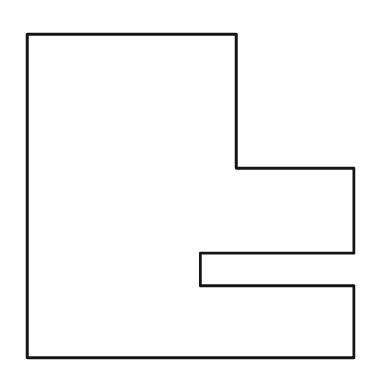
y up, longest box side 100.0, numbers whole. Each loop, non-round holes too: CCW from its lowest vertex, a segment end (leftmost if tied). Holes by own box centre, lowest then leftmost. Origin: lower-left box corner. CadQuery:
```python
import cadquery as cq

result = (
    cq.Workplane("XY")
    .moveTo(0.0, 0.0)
    .lineTo(100.0, 0.0)
    .lineTo(100.0, 22.0)
    .lineTo(53.0, 22.0)
    .lineTo(53.0, 32.0)
    .lineTo(100.0, 32.0)
    .lineTo(100.0, 58.0)
    .lineTo(64.0, 58.0)
    .lineTo(64.0, 99.0)
    .lineTo(0.0, 99.0)
    .close()
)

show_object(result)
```